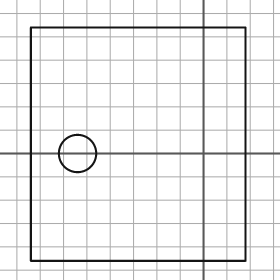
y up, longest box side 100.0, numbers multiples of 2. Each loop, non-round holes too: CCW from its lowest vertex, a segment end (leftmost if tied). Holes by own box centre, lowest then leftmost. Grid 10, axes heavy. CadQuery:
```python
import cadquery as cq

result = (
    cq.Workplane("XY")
    .moveTo(-74.0, -46.0)
    .lineTo(18.0, -46.0)
    .lineTo(18.0, 54.0)
    .lineTo(-74.0, 54.0)
    .close()
    .moveTo(-54.0, 0.0)
    .circle(8.0)
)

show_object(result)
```